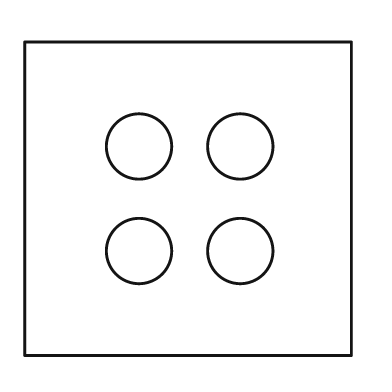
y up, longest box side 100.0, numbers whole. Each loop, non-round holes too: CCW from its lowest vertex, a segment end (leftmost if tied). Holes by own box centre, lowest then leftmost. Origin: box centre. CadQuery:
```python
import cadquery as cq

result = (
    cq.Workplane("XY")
    .moveTo(-50.0, -48.0)
    .lineTo(50.0, -48.0)
    .lineTo(50.0, 48.0)
    .lineTo(-50.0, 48.0)
    .close()
    .moveTo(-15.0, -16.0)
    .circle(10.0)
    .moveTo(16.0, -16.0)
    .circle(10.0)
    .moveTo(-15.0, 16.0)
    .circle(10.0)
    .moveTo(16.0, 16.0)
    .circle(10.0)
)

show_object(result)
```